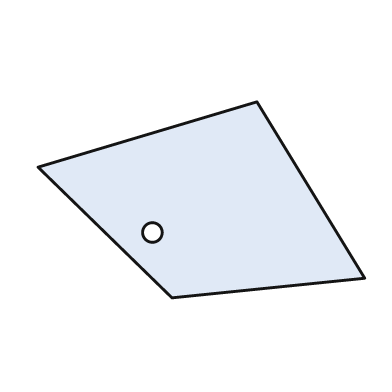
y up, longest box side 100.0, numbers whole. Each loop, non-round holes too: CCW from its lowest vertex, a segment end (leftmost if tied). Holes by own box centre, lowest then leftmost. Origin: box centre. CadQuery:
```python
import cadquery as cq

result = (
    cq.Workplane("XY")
    .moveTo(-9.0, -30.0)
    .lineTo(50.0, -24.0)
    .lineTo(17.0, 30.0)
    .lineTo(-50.0, 10.0)
    .close()
    .moveTo(-15.0, -10.0)
    .circle(3.0)
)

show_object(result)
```